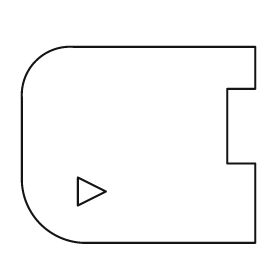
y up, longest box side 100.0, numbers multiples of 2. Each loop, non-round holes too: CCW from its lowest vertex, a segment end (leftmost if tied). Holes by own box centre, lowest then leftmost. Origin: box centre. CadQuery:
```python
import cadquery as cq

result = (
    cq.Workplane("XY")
    .moveTo(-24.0, -42.0)
    .lineTo(50.0, -42.0)
    .lineTo(50.0, -8.0)
    .lineTo(38.0, -8.0)
    .lineTo(38.0, 24.0)
    .lineTo(50.0, 24.0)
    .lineTo(50.0, 42.0)
    .lineTo(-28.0, 42.0)
    .threePointArc((-44.0, 36.0), (-50.0, 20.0))
    .lineTo(-50.0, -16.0)
    .threePointArc((-42.0, -34.0), (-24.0, -42.0))
    .close()
    .moveTo(-26.0, -26.0)
    .lineTo(-14.0, -20.0)
    .lineTo(-26.0, -14.0)
    .close()
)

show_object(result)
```